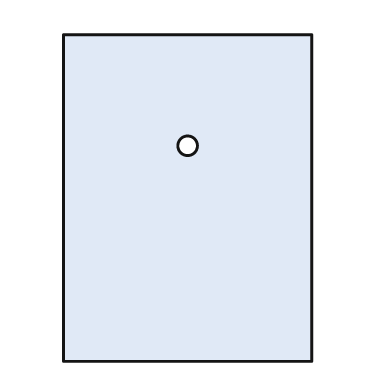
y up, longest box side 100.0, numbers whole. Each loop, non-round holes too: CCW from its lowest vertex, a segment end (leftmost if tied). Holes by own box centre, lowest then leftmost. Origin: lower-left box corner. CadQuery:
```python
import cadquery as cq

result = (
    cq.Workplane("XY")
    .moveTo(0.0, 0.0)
    .lineTo(76.0, 0.0)
    .lineTo(76.0, 100.0)
    .lineTo(0.0, 100.0)
    .close()
    .moveTo(38.0, 66.0)
    .circle(3.0)
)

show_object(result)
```